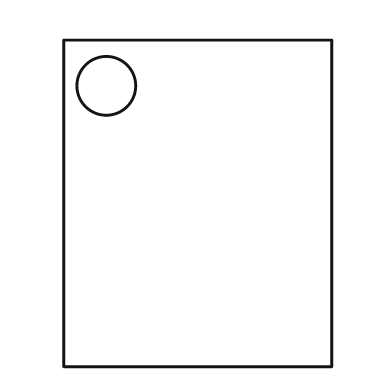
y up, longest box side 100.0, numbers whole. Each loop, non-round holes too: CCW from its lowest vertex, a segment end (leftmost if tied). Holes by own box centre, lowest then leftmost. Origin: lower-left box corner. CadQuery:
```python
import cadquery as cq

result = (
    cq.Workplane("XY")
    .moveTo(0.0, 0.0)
    .lineTo(82.0, 0.0)
    .lineTo(82.0, 100.0)
    .lineTo(0.0, 100.0)
    .close()
    .moveTo(13.0, 86.0)
    .circle(9.0)
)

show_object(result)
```